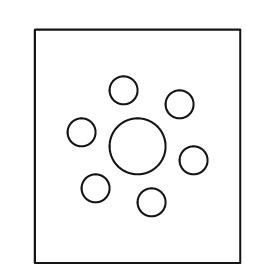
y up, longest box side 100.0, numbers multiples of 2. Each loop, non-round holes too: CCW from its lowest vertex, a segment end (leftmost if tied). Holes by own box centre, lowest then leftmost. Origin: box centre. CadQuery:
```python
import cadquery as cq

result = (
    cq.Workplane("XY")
    .moveTo(-44.0, -50.0)
    .lineTo(44.0, -50.0)
    .lineTo(44.0, 50.0)
    .lineTo(-44.0, 50.0)
    .close()
    .moveTo(6.0, -24.0)
    .circle(6.0)
    .moveTo(-18.0, -18.0)
    .circle(6.0)
    .moveTo(24.0, -6.0)
    .circle(6.0)
    .moveTo(0.0, 0.0)
    .circle(12.0)
    .moveTo(-24.0, 6.0)
    .circle(6.0)
    .moveTo(18.0, 18.0)
    .circle(6.0)
    .moveTo(-6.0, 24.0)
    .circle(6.0)
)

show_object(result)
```